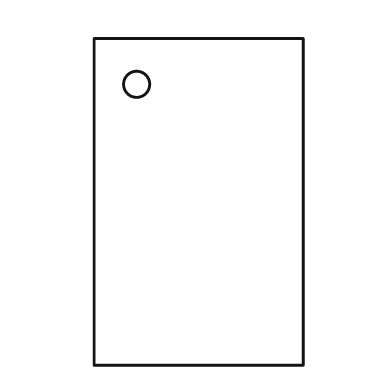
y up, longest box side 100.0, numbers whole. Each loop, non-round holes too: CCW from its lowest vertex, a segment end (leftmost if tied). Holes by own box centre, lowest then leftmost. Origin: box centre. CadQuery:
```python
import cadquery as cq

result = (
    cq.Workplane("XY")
    .moveTo(-32.0, -50.0)
    .lineTo(32.0, -50.0)
    .lineTo(32.0, 50.0)
    .lineTo(-32.0, 50.0)
    .close()
    .moveTo(-19.0, 36.0)
    .circle(4.0)
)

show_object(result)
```